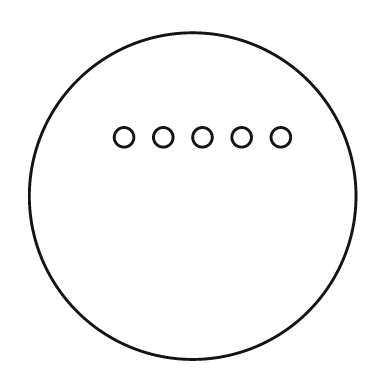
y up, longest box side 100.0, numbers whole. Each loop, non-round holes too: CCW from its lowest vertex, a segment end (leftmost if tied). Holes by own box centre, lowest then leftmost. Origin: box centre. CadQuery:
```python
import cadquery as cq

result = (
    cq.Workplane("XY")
    .moveTo(0.0, 0.0)
    .circle(50.0)
    .moveTo(-21.0, 18.0)
    .circle(3.0)
    .moveTo(-9.0, 18.0)
    .circle(3.0)
    .moveTo(3.0, 18.0)
    .circle(3.0)
    .moveTo(15.0, 18.0)
    .circle(3.0)
    .moveTo(27.0, 18.0)
    .circle(3.0)
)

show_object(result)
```